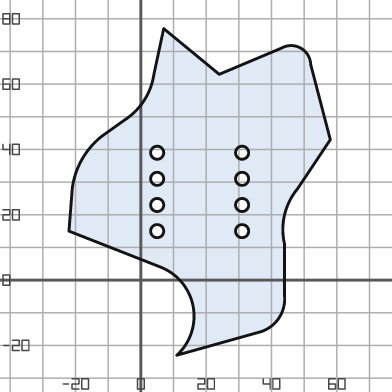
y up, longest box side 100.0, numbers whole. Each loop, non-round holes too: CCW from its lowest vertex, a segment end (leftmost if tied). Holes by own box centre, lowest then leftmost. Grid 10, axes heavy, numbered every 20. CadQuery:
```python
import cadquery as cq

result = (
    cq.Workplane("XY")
    .moveTo(11.0, -23.0)
    .lineTo(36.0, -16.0)
    .threePointArc((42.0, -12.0), (44.0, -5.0))
    .lineTo(44.0, 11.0)
    .threePointArc((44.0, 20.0), (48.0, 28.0))
    .lineTo(58.0, 43.0)
    .lineTo(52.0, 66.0)
    .threePointArc((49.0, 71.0), (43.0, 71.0))
    .lineTo(24.0, 63.0)
    .lineTo(7.0, 77.0)
    .lineTo(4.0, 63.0)
    .threePointArc((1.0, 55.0), (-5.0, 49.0))
    .lineTo(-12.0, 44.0)
    .threePointArc((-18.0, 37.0), (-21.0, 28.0))
    .lineTo(-22.0, 15.0)
    .lineTo(6.0, 4.0)
    .threePointArc((16.0, -8.0), (11.0, -23.0))
    .close()
    .moveTo(5.0, 15.0)
    .circle(2.0)
    .moveTo(31.0, 15.0)
    .circle(2.0)
    .moveTo(5.0, 23.0)
    .circle(2.0)
    .moveTo(31.0, 23.0)
    .circle(2.0)
    .moveTo(5.0, 31.0)
    .circle(2.0)
    .moveTo(31.0, 31.0)
    .circle(2.0)
    .moveTo(5.0, 39.0)
    .circle(2.0)
    .moveTo(31.0, 39.0)
    .circle(2.0)
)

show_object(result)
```